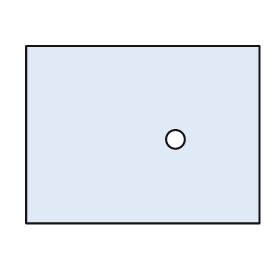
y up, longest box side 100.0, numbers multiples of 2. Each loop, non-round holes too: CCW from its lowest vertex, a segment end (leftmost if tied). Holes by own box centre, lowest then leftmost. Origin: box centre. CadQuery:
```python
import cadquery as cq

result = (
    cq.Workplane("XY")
    .moveTo(-50.0, -38.0)
    .lineTo(50.0, -38.0)
    .lineTo(50.0, 38.0)
    .lineTo(-50.0, 38.0)
    .close()
    .moveTo(14.0, -2.0)
    .circle(4.0)
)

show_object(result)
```